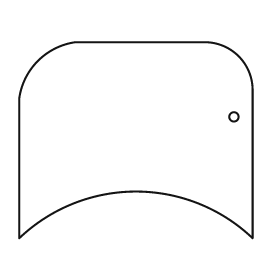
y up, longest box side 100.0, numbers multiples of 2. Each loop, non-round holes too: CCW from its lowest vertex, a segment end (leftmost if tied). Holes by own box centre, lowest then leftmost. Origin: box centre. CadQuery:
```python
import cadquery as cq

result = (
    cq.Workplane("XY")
    .moveTo(-50.0, -42.0)
    .threePointArc((0.0, -22.0), (50.0, -42.0))
    .lineTo(50.0, 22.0)
    .threePointArc((44.0, 36.0), (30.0, 42.0))
    .lineTo(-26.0, 42.0)
    .threePointArc((-42.0, 34.0), (-50.0, 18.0))
    .close()
    .moveTo(42.0, 10.0)
    .circle(2.0)
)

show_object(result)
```